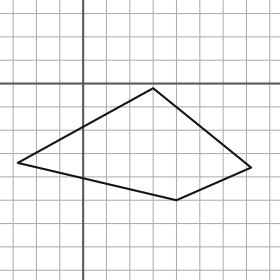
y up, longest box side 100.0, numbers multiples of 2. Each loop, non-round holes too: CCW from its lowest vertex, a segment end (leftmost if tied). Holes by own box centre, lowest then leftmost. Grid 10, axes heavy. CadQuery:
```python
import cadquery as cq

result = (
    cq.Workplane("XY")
    .moveTo(40.0, -50.0)
    .lineTo(72.0, -36.0)
    .lineTo(30.0, -2.0)
    .lineTo(-28.0, -34.0)
    .close()
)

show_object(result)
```